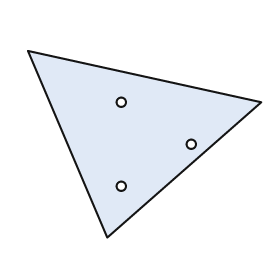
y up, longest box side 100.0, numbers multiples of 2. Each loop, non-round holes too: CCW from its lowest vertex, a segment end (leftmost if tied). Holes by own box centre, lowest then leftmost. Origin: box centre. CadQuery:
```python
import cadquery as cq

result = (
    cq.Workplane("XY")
    .moveTo(-16.0, -40.0)
    .lineTo(50.0, 18.0)
    .lineTo(-50.0, 40.0)
    .close()
    .moveTo(-10.0, -18.0)
    .circle(2.0)
    .moveTo(20.0, 0.0)
    .circle(2.0)
    .moveTo(-10.0, 18.0)
    .circle(2.0)
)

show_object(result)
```